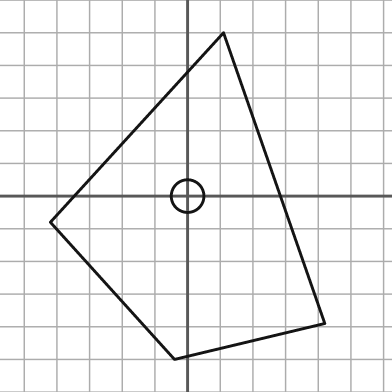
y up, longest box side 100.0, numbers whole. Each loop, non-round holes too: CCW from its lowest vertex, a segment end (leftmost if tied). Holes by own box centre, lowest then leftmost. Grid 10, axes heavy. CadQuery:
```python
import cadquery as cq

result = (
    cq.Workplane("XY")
    .moveTo(-4.0, -50.0)
    .lineTo(42.0, -39.0)
    .lineTo(11.0, 50.0)
    .lineTo(-42.0, -8.0)
    .close()
    .moveTo(0.0, 0.0)
    .circle(5.0)
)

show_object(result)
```